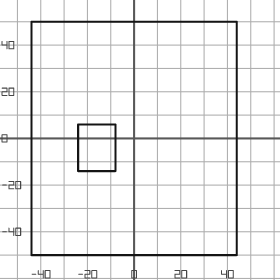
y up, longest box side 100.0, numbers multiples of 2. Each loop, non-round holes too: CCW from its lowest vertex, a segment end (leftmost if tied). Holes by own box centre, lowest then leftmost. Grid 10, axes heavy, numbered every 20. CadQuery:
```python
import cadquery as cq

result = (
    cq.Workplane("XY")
    .moveTo(-44.0, -50.0)
    .lineTo(44.0, -50.0)
    .lineTo(44.0, 50.0)
    .lineTo(-44.0, 50.0)
    .close()
    .moveTo(-24.0, -14.0)
    .lineTo(-8.0, -14.0)
    .lineTo(-8.0, 6.0)
    .lineTo(-24.0, 6.0)
    .close()
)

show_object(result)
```